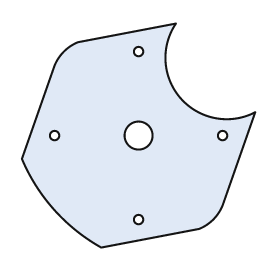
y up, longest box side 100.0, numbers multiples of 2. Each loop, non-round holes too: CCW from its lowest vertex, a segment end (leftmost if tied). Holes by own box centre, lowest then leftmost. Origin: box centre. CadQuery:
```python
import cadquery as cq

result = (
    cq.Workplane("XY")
    .moveTo(-16.0, -48.0)
    .lineTo(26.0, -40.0)
    .threePointArc((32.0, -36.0), (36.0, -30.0))
    .lineTo(50.0, 10.0)
    .threePointArc((18.0, 16.0), (16.0, 48.0))
    .lineTo(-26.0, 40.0)
    .threePointArc((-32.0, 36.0), (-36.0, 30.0))
    .lineTo(-50.0, -10.0)
    .threePointArc((-36.0, -32.0), (-16.0, -48.0))
    .close()
    .moveTo(0.0, -36.0)
    .circle(2.0)
    .moveTo(-36.0, 0.0)
    .circle(2.0)
    .moveTo(0.0, 0.0)
    .circle(6.0)
    .moveTo(36.0, 0.0)
    .circle(2.0)
    .moveTo(0.0, 36.0)
    .circle(2.0)
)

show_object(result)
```